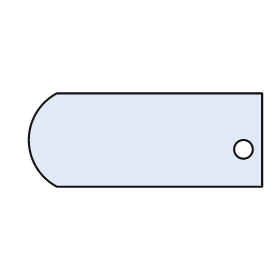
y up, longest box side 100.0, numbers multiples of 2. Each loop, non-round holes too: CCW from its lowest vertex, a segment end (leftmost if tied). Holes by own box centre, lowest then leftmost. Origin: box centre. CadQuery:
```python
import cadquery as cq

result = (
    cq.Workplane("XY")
    .moveTo(-38.0, -20.0)
    .lineTo(50.0, -20.0)
    .lineTo(50.0, 20.0)
    .lineTo(-38.0, 20.0)
    .threePointArc((-50.0, 0.0), (-38.0, -20.0))
    .close()
    .moveTo(42.0, -4.0)
    .circle(4.0)
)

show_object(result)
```